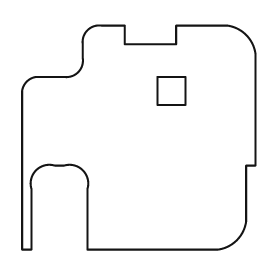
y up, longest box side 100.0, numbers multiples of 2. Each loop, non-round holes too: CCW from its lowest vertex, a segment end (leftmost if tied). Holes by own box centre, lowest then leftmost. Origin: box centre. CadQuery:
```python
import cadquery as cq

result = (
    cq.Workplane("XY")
    .moveTo(-50.0, -48.0)
    .lineTo(-46.0, -48.0)
    .lineTo(-46.0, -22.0)
    .threePointArc((-44.0, -14.0), (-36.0, -12.0))
    .lineTo(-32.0, -12.0)
    .threePointArc((-24.0, -14.0), (-22.0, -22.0))
    .lineTo(-22.0, -48.0)
    .lineTo(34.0, -48.0)
    .threePointArc((42.0, -44.0), (46.0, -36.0))
    .lineTo(46.0, -12.0)
    .lineTo(50.0, -12.0)
    .lineTo(50.0, 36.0)
    .threePointArc((46.0, 44.0), (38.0, 48.0))
    .lineTo(16.0, 48.0)
    .lineTo(16.0, 40.0)
    .lineTo(-6.0, 40.0)
    .lineTo(-6.0, 48.0)
    .lineTo(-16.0, 48.0)
    .threePointArc((-22.0, 46.0), (-24.0, 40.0))
    .lineTo(-24.0, 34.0)
    .threePointArc((-26.0, 28.0), (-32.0, 26.0))
    .lineTo(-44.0, 26.0)
    .threePointArc((-48.0, 24.0), (-50.0, 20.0))
    .close()
    .moveTo(8.0, 14.0)
    .lineTo(20.0, 14.0)
    .lineTo(20.0, 26.0)
    .lineTo(8.0, 26.0)
    .close()
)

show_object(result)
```